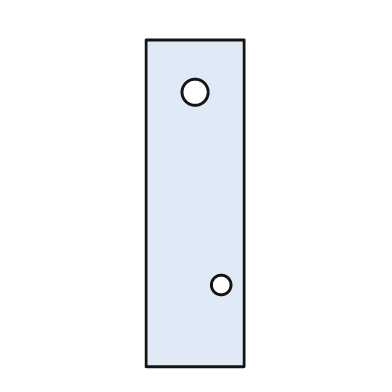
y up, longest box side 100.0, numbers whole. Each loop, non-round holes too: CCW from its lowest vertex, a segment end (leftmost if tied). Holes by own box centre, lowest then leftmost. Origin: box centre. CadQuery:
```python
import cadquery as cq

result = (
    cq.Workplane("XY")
    .moveTo(-15.0, -50.0)
    .lineTo(15.0, -50.0)
    .lineTo(15.0, 50.0)
    .lineTo(-15.0, 50.0)
    .close()
    .moveTo(8.0, -25.0)
    .circle(3.0)
    .moveTo(0.0, 34.0)
    .circle(4.0)
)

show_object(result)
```